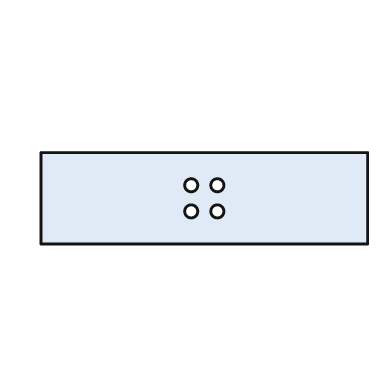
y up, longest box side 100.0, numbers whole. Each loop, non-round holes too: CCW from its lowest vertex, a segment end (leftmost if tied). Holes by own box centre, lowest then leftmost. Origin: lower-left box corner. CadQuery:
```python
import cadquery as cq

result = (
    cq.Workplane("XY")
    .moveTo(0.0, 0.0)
    .lineTo(100.0, 0.0)
    .lineTo(100.0, 28.0)
    .lineTo(0.0, 28.0)
    .close()
    .moveTo(46.0, 10.0)
    .circle(2.0)
    .moveTo(54.0, 10.0)
    .circle(2.0)
    .moveTo(46.0, 18.0)
    .circle(2.0)
    .moveTo(54.0, 18.0)
    .circle(2.0)
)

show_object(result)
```